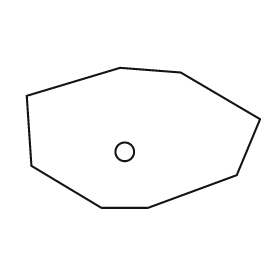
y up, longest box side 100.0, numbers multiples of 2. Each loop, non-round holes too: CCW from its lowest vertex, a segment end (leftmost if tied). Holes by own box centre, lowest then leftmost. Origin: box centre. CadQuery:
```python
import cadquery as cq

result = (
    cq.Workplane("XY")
    .moveTo(-18.0, -30.0)
    .lineTo(2.0, -30.0)
    .lineTo(40.0, -16.0)
    .lineTo(50.0, 8.0)
    .lineTo(16.0, 28.0)
    .lineTo(-10.0, 30.0)
    .lineTo(-50.0, 18.0)
    .lineTo(-48.0, -12.0)
    .close()
    .moveTo(-8.0, -6.0)
    .circle(4.0)
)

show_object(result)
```